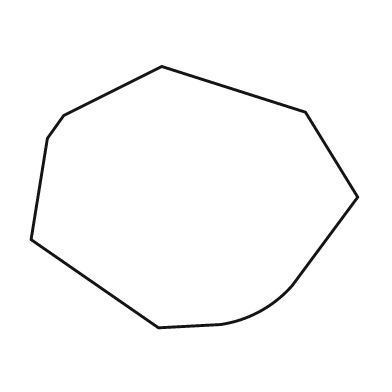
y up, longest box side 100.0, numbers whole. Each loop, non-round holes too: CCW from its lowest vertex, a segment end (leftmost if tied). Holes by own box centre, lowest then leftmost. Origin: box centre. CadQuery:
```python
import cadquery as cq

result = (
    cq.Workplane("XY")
    .moveTo(-11.0, -40.0)
    .lineTo(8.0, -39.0)
    .threePointArc((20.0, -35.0), (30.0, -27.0))
    .lineTo(50.0, 0.0)
    .lineTo(34.0, 26.0)
    .lineTo(-10.0, 40.0)
    .lineTo(-40.0, 25.0)
    .lineTo(-45.0, 18.0)
    .lineTo(-50.0, -13.0)
    .close()
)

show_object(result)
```